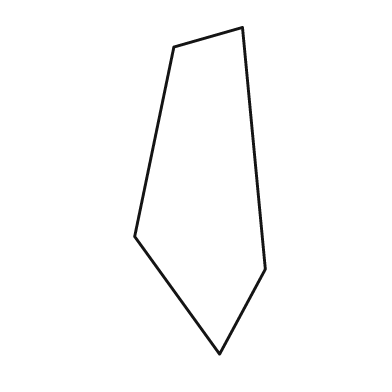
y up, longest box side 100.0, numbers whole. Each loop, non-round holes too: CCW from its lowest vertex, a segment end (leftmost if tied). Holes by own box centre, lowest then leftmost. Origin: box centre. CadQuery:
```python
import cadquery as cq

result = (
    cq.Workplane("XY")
    .moveTo(6.0, -50.0)
    .lineTo(20.0, -24.0)
    .lineTo(13.0, 50.0)
    .lineTo(-8.0, 44.0)
    .lineTo(-20.0, -14.0)
    .close()
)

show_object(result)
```